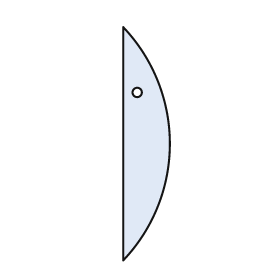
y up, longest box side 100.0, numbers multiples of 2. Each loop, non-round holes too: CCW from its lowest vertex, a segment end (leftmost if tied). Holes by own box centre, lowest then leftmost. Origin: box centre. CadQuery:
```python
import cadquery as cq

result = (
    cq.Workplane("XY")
    .moveTo(-10.0, -50.0)
    .threePointArc((10.0, 0.0), (-10.0, 50.0))
    .close()
    .moveTo(-4.0, 22.0)
    .circle(2.0)
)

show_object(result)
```